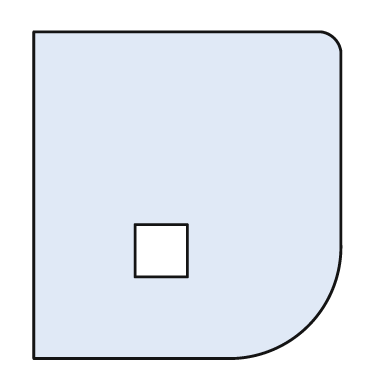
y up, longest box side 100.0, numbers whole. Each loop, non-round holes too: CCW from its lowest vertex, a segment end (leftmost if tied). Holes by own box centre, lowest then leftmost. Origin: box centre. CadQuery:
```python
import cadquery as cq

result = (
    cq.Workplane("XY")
    .moveTo(-47.0, -50.0)
    .lineTo(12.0, -50.0)
    .threePointArc((37.0, -40.0), (47.0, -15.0))
    .lineTo(47.0, 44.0)
    .threePointArc((45.0, 48.0), (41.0, 50.0))
    .lineTo(-47.0, 50.0)
    .close()
    .moveTo(-16.0, -25.0)
    .lineTo(0.0, -25.0)
    .lineTo(0.0, -9.0)
    .lineTo(-16.0, -9.0)
    .close()
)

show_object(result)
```